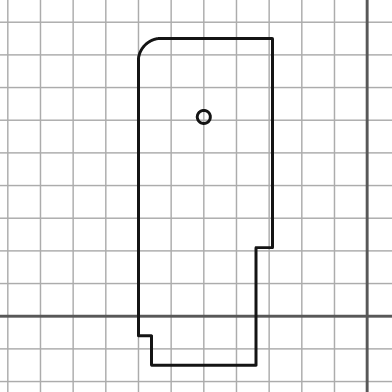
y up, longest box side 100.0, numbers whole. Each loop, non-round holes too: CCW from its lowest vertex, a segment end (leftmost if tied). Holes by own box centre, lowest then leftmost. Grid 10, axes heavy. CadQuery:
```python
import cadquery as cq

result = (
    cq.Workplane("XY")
    .moveTo(-66.0, -15.0)
    .lineTo(-34.0, -15.0)
    .lineTo(-34.0, 21.0)
    .lineTo(-29.0, 21.0)
    .lineTo(-29.0, 85.0)
    .lineTo(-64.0, 85.0)
    .threePointArc((-68.0, 83.0), (-70.0, 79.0))
    .lineTo(-70.0, -6.0)
    .lineTo(-66.0, -6.0)
    .close()
    .moveTo(-50.0, 61.0)
    .circle(2.0)
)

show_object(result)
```